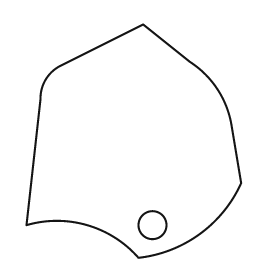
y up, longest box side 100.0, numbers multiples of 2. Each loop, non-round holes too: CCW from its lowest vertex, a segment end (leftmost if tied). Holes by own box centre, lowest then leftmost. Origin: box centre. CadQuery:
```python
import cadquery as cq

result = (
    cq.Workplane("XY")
    .moveTo(2.0, -50.0)
    .threePointArc((28.0, -40.0), (46.0, -18.0))
    .lineTo(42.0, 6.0)
    .threePointArc((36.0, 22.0), (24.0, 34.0))
    .lineTo(4.0, 50.0)
    .lineTo(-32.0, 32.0)
    .threePointArc((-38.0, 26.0), (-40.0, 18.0))
    .lineTo(-46.0, -36.0)
    .threePointArc((-20.0, -36.0), (2.0, -50.0))
    .close()
    .moveTo(8.0, -36.0)
    .circle(6.0)
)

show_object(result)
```